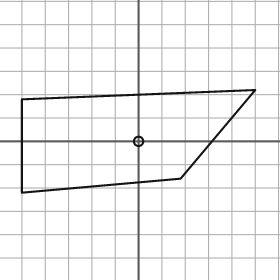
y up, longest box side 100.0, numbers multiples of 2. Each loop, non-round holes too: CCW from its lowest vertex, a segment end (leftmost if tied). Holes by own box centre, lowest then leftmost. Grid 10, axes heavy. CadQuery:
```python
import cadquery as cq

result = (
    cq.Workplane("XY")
    .moveTo(-50.0, -22.0)
    .lineTo(18.0, -16.0)
    .lineTo(50.0, 22.0)
    .lineTo(-50.0, 18.0)
    .close()
    .moveTo(0.0, 0.0)
    .circle(2.0)
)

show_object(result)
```